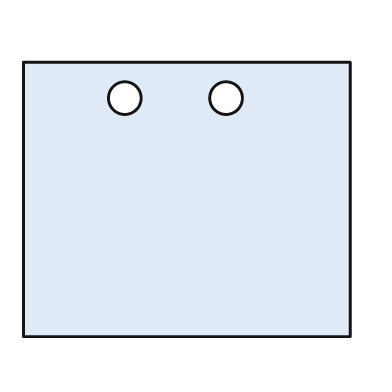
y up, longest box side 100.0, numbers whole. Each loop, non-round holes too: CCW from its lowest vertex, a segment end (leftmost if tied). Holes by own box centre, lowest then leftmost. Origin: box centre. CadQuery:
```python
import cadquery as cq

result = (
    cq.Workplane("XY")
    .moveTo(-50.0, -42.0)
    .lineTo(50.0, -42.0)
    .lineTo(50.0, 42.0)
    .lineTo(-50.0, 42.0)
    .close()
    .moveTo(-19.0, 31.0)
    .circle(5.0)
    .moveTo(12.0, 31.0)
    .circle(5.0)
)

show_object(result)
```